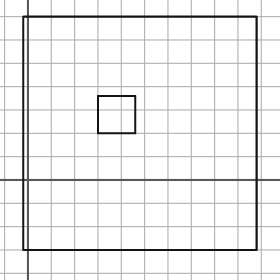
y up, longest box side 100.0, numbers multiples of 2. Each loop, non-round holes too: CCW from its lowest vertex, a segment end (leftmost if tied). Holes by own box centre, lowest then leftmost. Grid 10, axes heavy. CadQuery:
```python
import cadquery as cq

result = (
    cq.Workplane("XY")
    .moveTo(-2.0, -30.0)
    .lineTo(98.0, -30.0)
    .lineTo(98.0, 70.0)
    .lineTo(-2.0, 70.0)
    .close()
    .moveTo(30.0, 20.0)
    .lineTo(46.0, 20.0)
    .lineTo(46.0, 36.0)
    .lineTo(30.0, 36.0)
    .close()
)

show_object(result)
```